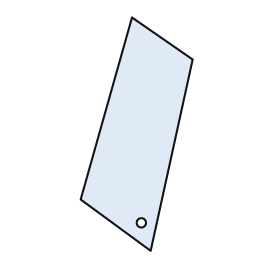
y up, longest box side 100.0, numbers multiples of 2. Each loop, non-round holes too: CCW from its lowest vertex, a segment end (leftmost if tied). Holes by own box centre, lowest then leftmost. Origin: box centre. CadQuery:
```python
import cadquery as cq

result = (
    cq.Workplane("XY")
    .moveTo(6.0, -50.0)
    .lineTo(24.0, 32.0)
    .lineTo(-2.0, 50.0)
    .lineTo(-24.0, -28.0)
    .close()
    .moveTo(2.0, -38.0)
    .circle(2.0)
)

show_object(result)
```